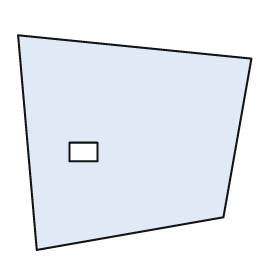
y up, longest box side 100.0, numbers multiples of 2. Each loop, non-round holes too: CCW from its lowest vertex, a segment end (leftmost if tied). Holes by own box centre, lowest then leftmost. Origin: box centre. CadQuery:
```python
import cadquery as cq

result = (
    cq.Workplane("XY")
    .moveTo(-42.0, -46.0)
    .lineTo(38.0, -32.0)
    .lineTo(50.0, 36.0)
    .lineTo(-50.0, 46.0)
    .close()
    .moveTo(-28.0, -8.0)
    .lineTo(-16.0, -8.0)
    .lineTo(-16.0, 0.0)
    .lineTo(-28.0, 0.0)
    .close()
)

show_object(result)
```